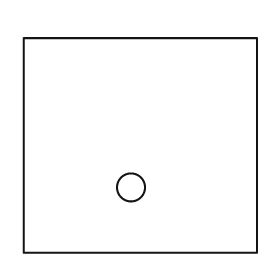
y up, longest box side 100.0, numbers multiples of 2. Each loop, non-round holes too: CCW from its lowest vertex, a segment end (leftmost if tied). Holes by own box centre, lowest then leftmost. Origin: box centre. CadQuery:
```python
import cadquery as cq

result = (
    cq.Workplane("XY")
    .moveTo(-50.0, -46.0)
    .lineTo(50.0, -46.0)
    .lineTo(50.0, 46.0)
    .lineTo(-50.0, 46.0)
    .close()
    .moveTo(-4.0, -18.0)
    .circle(6.0)
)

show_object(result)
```